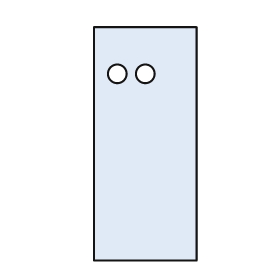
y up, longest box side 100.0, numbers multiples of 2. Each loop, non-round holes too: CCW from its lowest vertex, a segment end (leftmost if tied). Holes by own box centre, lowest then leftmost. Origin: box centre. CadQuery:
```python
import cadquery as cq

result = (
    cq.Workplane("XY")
    .moveTo(-22.0, -50.0)
    .lineTo(22.0, -50.0)
    .lineTo(22.0, 50.0)
    .lineTo(-22.0, 50.0)
    .close()
    .moveTo(-12.0, 30.0)
    .circle(4.0)
    .moveTo(0.0, 30.0)
    .circle(4.0)
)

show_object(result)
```